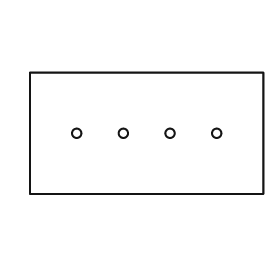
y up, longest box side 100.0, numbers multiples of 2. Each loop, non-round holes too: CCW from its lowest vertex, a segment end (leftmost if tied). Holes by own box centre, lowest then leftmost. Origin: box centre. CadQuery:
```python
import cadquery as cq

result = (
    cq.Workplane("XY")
    .moveTo(-50.0, -26.0)
    .lineTo(50.0, -26.0)
    .lineTo(50.0, 26.0)
    .lineTo(-50.0, 26.0)
    .close()
    .moveTo(-30.0, 0.0)
    .circle(2.0)
    .moveTo(-10.0, 0.0)
    .circle(2.0)
    .moveTo(10.0, 0.0)
    .circle(2.0)
    .moveTo(30.0, 0.0)
    .circle(2.0)
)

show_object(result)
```